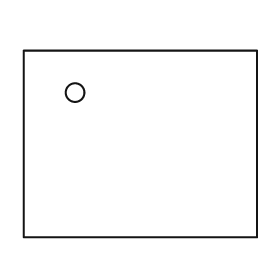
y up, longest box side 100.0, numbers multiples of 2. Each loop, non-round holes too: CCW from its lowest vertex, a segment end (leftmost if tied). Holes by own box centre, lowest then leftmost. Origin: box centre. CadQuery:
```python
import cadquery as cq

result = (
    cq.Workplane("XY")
    .moveTo(-50.0, -40.0)
    .lineTo(50.0, -40.0)
    .lineTo(50.0, 40.0)
    .lineTo(-50.0, 40.0)
    .close()
    .moveTo(-28.0, 22.0)
    .circle(4.0)
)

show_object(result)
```